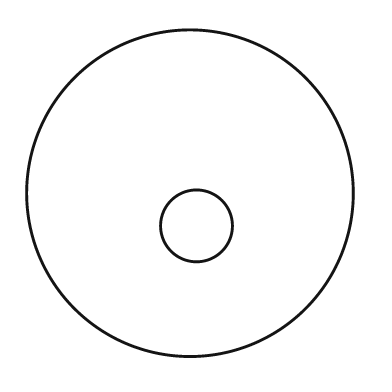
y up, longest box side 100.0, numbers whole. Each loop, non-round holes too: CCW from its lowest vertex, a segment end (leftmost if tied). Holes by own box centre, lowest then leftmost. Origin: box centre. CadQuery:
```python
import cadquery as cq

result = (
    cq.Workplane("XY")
    .moveTo(0.0, 0.0)
    .circle(50.0)
    .moveTo(2.0, -10.0)
    .circle(11.0)
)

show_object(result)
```